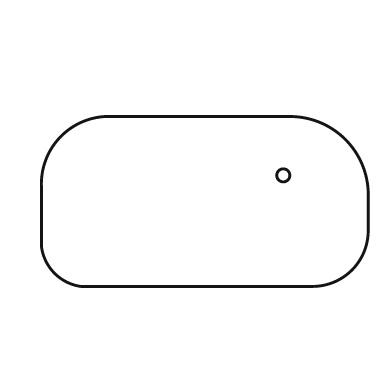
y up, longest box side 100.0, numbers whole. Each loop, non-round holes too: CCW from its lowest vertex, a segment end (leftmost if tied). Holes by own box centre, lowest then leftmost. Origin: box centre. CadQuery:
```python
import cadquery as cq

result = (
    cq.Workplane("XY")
    .moveTo(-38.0, -26.0)
    .lineTo(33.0, -26.0)
    .threePointArc((45.0, -21.0), (50.0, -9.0))
    .lineTo(50.0, 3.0)
    .threePointArc((43.0, 19.0), (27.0, 26.0))
    .lineTo(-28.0, 26.0)
    .threePointArc((-44.0, 20.0), (-50.0, 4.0))
    .lineTo(-50.0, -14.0)
    .threePointArc((-46.0, -22.0), (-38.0, -26.0))
    .close()
    .moveTo(24.0, 8.0)
    .circle(2.0)
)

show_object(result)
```